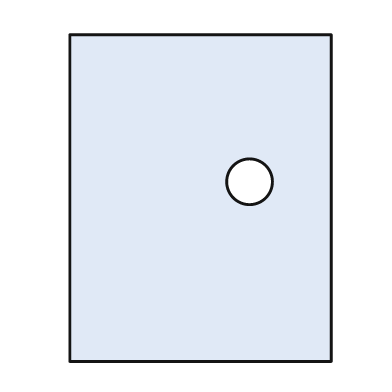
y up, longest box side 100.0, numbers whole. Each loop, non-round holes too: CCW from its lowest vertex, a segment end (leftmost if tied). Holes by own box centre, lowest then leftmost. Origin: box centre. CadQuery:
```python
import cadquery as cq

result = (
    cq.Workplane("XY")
    .moveTo(-40.0, -50.0)
    .lineTo(40.0, -50.0)
    .lineTo(40.0, 50.0)
    .lineTo(-40.0, 50.0)
    .close()
    .moveTo(15.0, 5.0)
    .circle(7.0)
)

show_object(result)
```